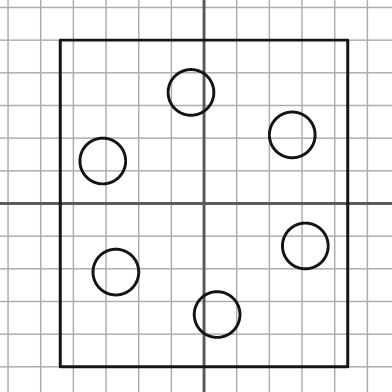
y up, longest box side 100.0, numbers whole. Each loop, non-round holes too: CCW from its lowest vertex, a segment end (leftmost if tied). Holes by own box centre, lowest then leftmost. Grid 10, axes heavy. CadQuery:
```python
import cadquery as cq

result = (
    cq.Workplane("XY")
    .moveTo(-44.0, -50.0)
    .lineTo(44.0, -50.0)
    .lineTo(44.0, 50.0)
    .lineTo(-44.0, 50.0)
    .close()
    .moveTo(4.0, -34.0)
    .circle(7.0)
    .moveTo(-27.0, -21.0)
    .circle(7.0)
    .moveTo(31.0, -13.0)
    .circle(7.0)
    .moveTo(-31.0, 13.0)
    .circle(7.0)
    .moveTo(27.0, 21.0)
    .circle(7.0)
    .moveTo(-4.0, 34.0)
    .circle(7.0)
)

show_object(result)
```